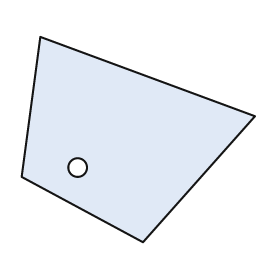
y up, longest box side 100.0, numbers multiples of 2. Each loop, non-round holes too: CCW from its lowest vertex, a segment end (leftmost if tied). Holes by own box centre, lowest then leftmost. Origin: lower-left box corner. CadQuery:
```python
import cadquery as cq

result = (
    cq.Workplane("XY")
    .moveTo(52.0, 0.0)
    .lineTo(100.0, 54.0)
    .lineTo(8.0, 88.0)
    .lineTo(0.0, 28.0)
    .close()
    .moveTo(24.0, 32.0)
    .circle(4.0)
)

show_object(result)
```